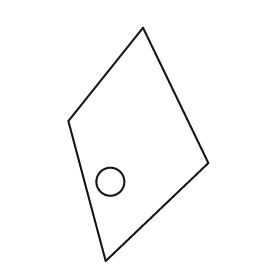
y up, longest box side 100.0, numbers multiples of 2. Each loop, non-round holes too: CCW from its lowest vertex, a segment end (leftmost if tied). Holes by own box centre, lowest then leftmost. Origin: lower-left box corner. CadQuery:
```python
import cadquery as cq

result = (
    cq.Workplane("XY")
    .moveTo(16.0, 0.0)
    .lineTo(60.0, 42.0)
    .lineTo(32.0, 100.0)
    .lineTo(0.0, 60.0)
    .close()
    .moveTo(18.0, 34.0)
    .circle(6.0)
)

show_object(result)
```